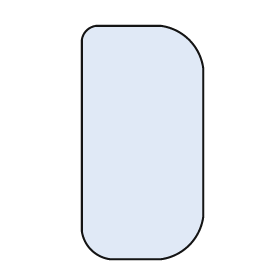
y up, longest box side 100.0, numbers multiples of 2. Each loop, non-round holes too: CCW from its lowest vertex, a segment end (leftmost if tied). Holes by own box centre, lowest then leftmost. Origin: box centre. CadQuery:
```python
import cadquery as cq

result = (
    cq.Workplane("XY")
    .moveTo(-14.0, -50.0)
    .lineTo(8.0, -50.0)
    .threePointArc((20.0, -44.0), (26.0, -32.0))
    .lineTo(26.0, 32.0)
    .threePointArc((20.0, 44.0), (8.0, 50.0))
    .lineTo(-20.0, 50.0)
    .threePointArc((-24.0, 48.0), (-26.0, 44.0))
    .lineTo(-26.0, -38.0)
    .threePointArc((-22.0, -46.0), (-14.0, -50.0))
    .close()
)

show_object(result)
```